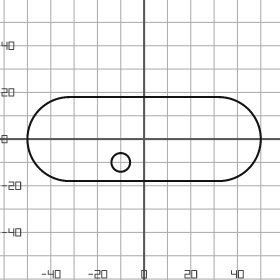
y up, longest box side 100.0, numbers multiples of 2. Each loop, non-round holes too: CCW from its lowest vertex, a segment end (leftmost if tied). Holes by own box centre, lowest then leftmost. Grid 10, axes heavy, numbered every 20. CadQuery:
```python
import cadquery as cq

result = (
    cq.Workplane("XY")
    .moveTo(-32.0, -18.0)
    .lineTo(32.0, -18.0)
    .threePointArc((50.0, 0.0), (32.0, 18.0))
    .lineTo(-32.0, 18.0)
    .threePointArc((-50.0, 0.0), (-32.0, -18.0))
    .close()
    .moveTo(-10.0, -10.0)
    .circle(4.0)
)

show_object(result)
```